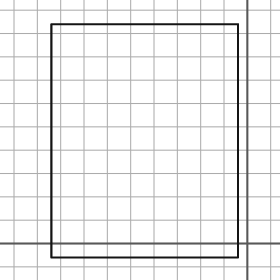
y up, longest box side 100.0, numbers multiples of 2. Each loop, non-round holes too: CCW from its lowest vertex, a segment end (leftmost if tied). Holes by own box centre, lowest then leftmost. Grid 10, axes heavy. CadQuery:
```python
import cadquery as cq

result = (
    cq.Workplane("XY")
    .moveTo(-84.0, -6.0)
    .lineTo(-4.0, -6.0)
    .lineTo(-4.0, 94.0)
    .lineTo(-84.0, 94.0)
    .close()
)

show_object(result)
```